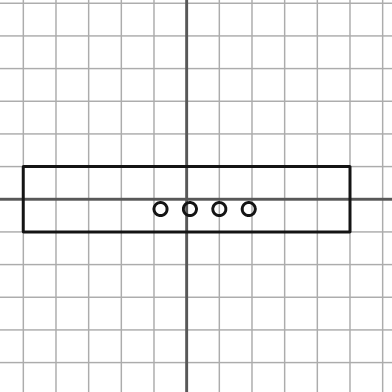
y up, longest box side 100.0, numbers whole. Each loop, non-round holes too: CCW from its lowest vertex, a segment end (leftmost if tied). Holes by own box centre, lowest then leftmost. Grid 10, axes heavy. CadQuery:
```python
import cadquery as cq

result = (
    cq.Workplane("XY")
    .moveTo(-50.0, -10.0)
    .lineTo(50.0, -10.0)
    .lineTo(50.0, 10.0)
    .lineTo(-50.0, 10.0)
    .close()
    .moveTo(-8.0, -3.0)
    .circle(2.0)
    .moveTo(1.0, -3.0)
    .circle(2.0)
    .moveTo(10.0, -3.0)
    .circle(2.0)
    .moveTo(19.0, -3.0)
    .circle(2.0)
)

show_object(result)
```